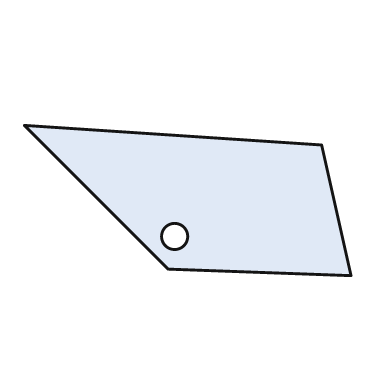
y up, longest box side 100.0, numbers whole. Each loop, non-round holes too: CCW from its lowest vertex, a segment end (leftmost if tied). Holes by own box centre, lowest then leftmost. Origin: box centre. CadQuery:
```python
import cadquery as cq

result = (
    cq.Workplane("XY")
    .moveTo(50.0, -23.0)
    .lineTo(41.0, 17.0)
    .lineTo(-50.0, 23.0)
    .lineTo(-6.0, -21.0)
    .close()
    .moveTo(-4.0, -11.0)
    .circle(4.0)
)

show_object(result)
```